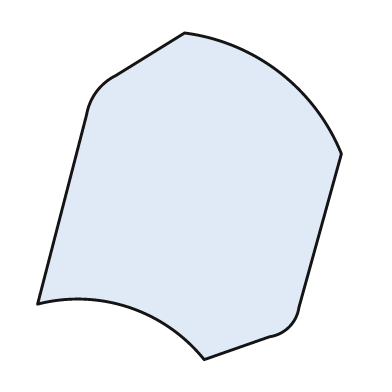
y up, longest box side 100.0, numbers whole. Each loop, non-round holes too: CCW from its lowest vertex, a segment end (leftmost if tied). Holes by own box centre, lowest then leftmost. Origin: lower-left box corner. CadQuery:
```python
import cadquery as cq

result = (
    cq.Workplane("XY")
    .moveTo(51.0, 0.0)
    .lineTo(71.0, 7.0)
    .threePointArc((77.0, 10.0), (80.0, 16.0))
    .lineTo(93.0, 63.0)
    .threePointArc((74.0, 88.0), (45.0, 100.0))
    .lineTo(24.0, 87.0)
    .threePointArc((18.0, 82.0), (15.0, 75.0))
    .lineTo(0.0, 17.0)
    .threePointArc((28.0, 16.0), (51.0, 0.0))
    .close()
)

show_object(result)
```